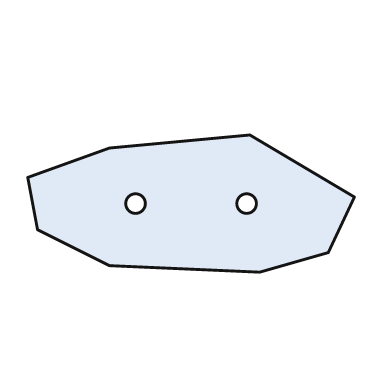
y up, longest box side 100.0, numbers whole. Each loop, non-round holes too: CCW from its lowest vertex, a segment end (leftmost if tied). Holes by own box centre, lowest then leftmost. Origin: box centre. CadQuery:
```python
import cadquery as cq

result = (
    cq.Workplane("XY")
    .moveTo(21.0, -21.0)
    .lineTo(42.0, -15.0)
    .lineTo(50.0, 2.0)
    .lineTo(18.0, 21.0)
    .lineTo(-25.0, 17.0)
    .lineTo(-50.0, 8.0)
    .lineTo(-47.0, -8.0)
    .lineTo(-25.0, -19.0)
    .close()
    .moveTo(-17.0, 0.0)
    .circle(3.0)
    .moveTo(17.0, 0.0)
    .circle(3.0)
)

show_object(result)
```